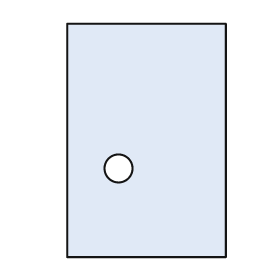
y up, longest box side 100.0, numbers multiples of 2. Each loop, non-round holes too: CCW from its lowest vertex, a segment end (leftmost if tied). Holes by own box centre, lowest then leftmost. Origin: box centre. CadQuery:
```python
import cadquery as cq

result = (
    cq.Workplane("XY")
    .moveTo(-34.0, -50.0)
    .lineTo(34.0, -50.0)
    .lineTo(34.0, 50.0)
    .lineTo(-34.0, 50.0)
    .close()
    .moveTo(-12.0, -12.0)
    .circle(6.0)
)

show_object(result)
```